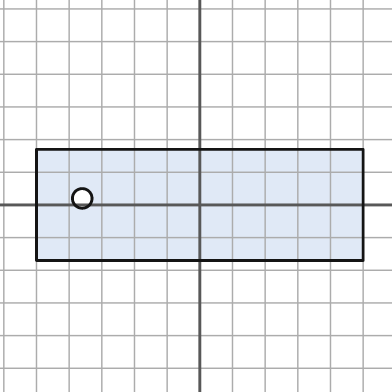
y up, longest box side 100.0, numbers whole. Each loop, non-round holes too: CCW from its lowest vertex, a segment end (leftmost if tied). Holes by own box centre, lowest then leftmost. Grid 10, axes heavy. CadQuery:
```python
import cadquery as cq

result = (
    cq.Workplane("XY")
    .moveTo(-50.0, -17.0)
    .lineTo(50.0, -17.0)
    .lineTo(50.0, 17.0)
    .lineTo(-50.0, 17.0)
    .close()
    .moveTo(-36.0, 2.0)
    .circle(3.0)
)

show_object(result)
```